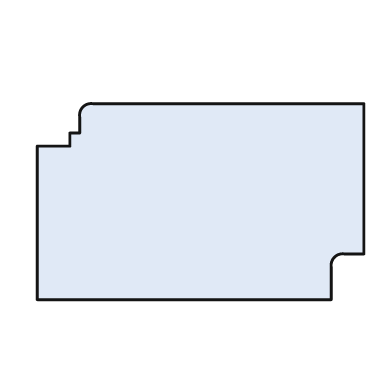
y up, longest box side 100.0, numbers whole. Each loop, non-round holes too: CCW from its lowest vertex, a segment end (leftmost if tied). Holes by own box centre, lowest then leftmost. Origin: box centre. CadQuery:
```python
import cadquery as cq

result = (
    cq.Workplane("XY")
    .moveTo(-50.0, -30.0)
    .lineTo(40.0, -30.0)
    .lineTo(40.0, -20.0)
    .threePointArc((41.0, -17.0), (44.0, -16.0))
    .lineTo(50.0, -16.0)
    .lineTo(50.0, 30.0)
    .lineTo(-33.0, 30.0)
    .threePointArc((-36.0, 29.0), (-37.0, 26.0))
    .lineTo(-37.0, 21.0)
    .lineTo(-40.0, 21.0)
    .lineTo(-40.0, 17.0)
    .lineTo(-50.0, 17.0)
    .close()
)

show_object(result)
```